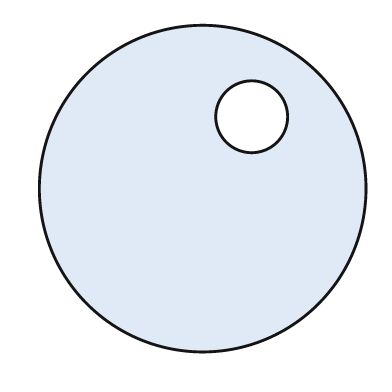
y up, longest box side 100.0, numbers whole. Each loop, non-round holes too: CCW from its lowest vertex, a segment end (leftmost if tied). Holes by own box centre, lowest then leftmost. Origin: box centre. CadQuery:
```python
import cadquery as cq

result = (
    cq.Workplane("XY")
    .moveTo(0.0, 0.0)
    .circle(50.0)
    .moveTo(15.0, 22.0)
    .circle(11.0)
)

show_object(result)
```